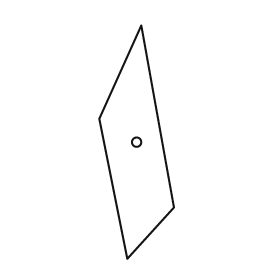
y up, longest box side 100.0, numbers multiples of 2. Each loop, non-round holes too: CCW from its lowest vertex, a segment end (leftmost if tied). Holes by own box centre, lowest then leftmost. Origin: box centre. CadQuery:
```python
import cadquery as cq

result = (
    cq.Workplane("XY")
    .moveTo(-4.0, -50.0)
    .lineTo(16.0, -28.0)
    .lineTo(2.0, 50.0)
    .lineTo(-16.0, 10.0)
    .close()
    .moveTo(0.0, 0.0)
    .circle(2.0)
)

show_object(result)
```